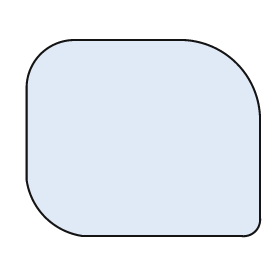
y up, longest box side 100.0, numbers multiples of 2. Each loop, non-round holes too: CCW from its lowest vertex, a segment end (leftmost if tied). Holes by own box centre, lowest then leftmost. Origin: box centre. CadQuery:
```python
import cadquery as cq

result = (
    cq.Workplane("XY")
    .moveTo(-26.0, -42.0)
    .lineTo(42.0, -42.0)
    .threePointArc((48.0, -40.0), (50.0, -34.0))
    .lineTo(50.0, 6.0)
    .threePointArc((40.0, 32.0), (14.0, 42.0))
    .lineTo(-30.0, 42.0)
    .threePointArc((-44.0, 36.0), (-50.0, 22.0))
    .lineTo(-50.0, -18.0)
    .threePointArc((-42.0, -34.0), (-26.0, -42.0))
    .close()
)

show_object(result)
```